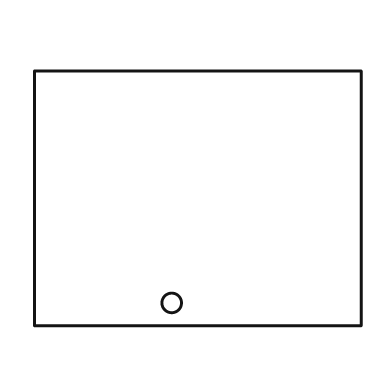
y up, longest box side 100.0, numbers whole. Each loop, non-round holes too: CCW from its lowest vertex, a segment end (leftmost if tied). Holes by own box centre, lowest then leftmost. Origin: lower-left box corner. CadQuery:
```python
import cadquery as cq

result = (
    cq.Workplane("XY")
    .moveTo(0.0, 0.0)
    .lineTo(100.0, 0.0)
    .lineTo(100.0, 78.0)
    .lineTo(0.0, 78.0)
    .close()
    .moveTo(42.0, 7.0)
    .circle(3.0)
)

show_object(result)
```